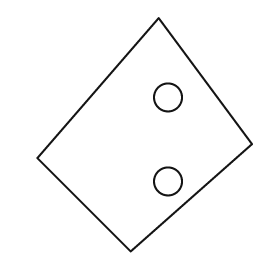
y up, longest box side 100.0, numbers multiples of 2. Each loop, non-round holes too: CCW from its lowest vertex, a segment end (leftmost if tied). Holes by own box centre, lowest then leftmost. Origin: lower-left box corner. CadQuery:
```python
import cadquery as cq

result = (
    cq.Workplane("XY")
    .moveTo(40.0, 0.0)
    .lineTo(92.0, 46.0)
    .lineTo(52.0, 100.0)
    .lineTo(0.0, 40.0)
    .close()
    .moveTo(56.0, 30.0)
    .circle(6.0)
    .moveTo(56.0, 66.0)
    .circle(6.0)
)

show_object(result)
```